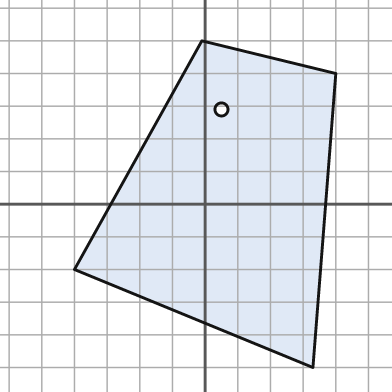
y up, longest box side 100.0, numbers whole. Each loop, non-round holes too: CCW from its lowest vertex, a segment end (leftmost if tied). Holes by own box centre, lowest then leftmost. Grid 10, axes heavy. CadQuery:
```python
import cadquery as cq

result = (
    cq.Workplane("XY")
    .moveTo(33.0, -50.0)
    .lineTo(40.0, 40.0)
    .lineTo(-1.0, 50.0)
    .lineTo(-40.0, -20.0)
    .close()
    .moveTo(5.0, 29.0)
    .circle(2.0)
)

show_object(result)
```